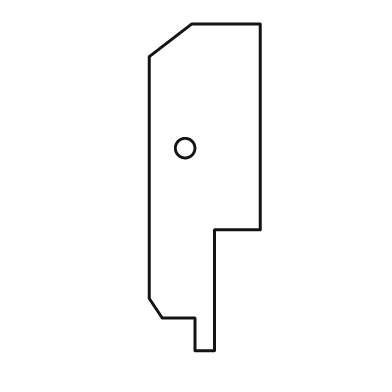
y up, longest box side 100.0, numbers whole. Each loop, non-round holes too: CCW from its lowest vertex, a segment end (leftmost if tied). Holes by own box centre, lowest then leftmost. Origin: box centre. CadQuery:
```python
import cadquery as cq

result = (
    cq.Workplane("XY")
    .moveTo(-3.0, -50.0)
    .lineTo(3.0, -50.0)
    .lineTo(3.0, -13.0)
    .lineTo(17.0, -13.0)
    .lineTo(17.0, 50.0)
    .lineTo(-4.0, 50.0)
    .lineTo(-17.0, 40.0)
    .lineTo(-17.0, -34.0)
    .lineTo(-13.0, -40.0)
    .lineTo(-3.0, -40.0)
    .close()
    .moveTo(-6.0, 12.0)
    .circle(3.0)
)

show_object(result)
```